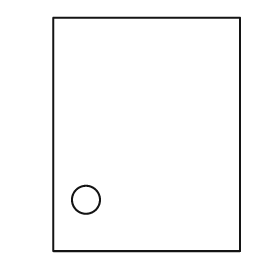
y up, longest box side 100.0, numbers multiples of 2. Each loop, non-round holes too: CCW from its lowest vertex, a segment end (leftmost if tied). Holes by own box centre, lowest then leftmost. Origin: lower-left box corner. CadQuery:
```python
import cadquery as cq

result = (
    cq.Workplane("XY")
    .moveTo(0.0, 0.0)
    .lineTo(80.0, 0.0)
    .lineTo(80.0, 100.0)
    .lineTo(0.0, 100.0)
    .close()
    .moveTo(14.0, 22.0)
    .circle(6.0)
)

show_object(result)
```